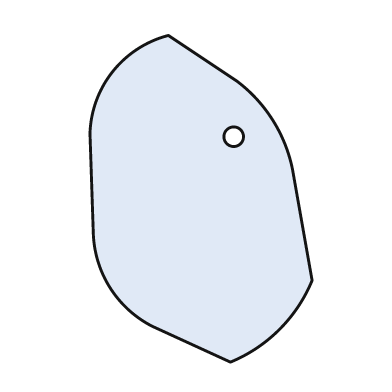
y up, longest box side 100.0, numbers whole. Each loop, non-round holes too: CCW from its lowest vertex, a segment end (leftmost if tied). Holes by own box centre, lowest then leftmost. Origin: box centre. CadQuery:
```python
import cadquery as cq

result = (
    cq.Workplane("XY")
    .moveTo(9.0, -50.0)
    .threePointArc((24.0, -40.0), (34.0, -25.0))
    .lineTo(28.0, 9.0)
    .threePointArc((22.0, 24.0), (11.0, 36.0))
    .lineTo(-10.0, 50.0)
    .threePointArc((-27.0, 39.0), (-34.0, 20.0))
    .lineTo(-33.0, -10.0)
    .threePointArc((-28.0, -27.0), (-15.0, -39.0))
    .close()
    .moveTo(10.0, 19.0)
    .circle(3.0)
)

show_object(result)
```